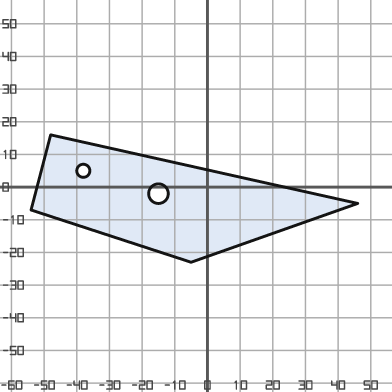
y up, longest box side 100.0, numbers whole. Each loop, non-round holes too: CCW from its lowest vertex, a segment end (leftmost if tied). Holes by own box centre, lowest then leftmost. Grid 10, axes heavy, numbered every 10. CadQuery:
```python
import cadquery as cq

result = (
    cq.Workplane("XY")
    .moveTo(-5.0, -23.0)
    .lineTo(46.0, -5.0)
    .lineTo(-48.0, 16.0)
    .lineTo(-54.0, -7.0)
    .close()
    .moveTo(-15.0, -2.0)
    .circle(3.0)
    .moveTo(-38.0, 5.0)
    .circle(2.0)
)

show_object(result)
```